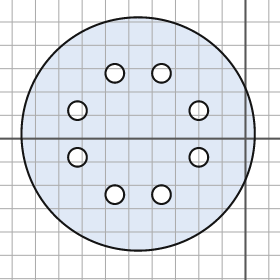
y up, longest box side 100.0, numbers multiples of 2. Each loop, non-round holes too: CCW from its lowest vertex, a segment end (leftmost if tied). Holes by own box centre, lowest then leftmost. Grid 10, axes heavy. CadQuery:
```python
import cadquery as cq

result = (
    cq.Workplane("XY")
    .moveTo(-46.0, 2.0)
    .circle(50.0)
    .moveTo(-56.0, -24.0)
    .circle(4.0)
    .moveTo(-36.0, -24.0)
    .circle(4.0)
    .moveTo(-72.0, -8.0)
    .circle(4.0)
    .moveTo(-20.0, -8.0)
    .circle(4.0)
    .moveTo(-72.0, 12.0)
    .circle(4.0)
    .moveTo(-20.0, 12.0)
    .circle(4.0)
    .moveTo(-56.0, 28.0)
    .circle(4.0)
    .moveTo(-36.0, 28.0)
    .circle(4.0)
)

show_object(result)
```